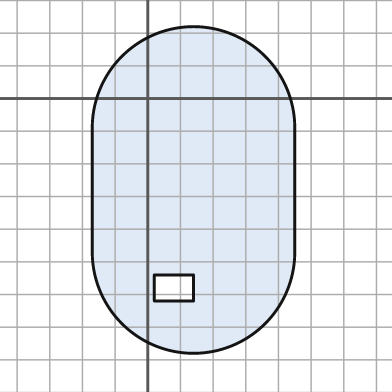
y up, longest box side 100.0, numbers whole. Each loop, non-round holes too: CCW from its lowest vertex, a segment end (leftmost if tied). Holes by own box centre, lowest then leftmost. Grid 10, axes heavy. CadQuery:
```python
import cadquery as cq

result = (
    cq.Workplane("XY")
    .moveTo(-17.0, -47.0)
    .threePointArc((14.0, -78.0), (45.0, -47.0))
    .lineTo(45.0, -9.0)
    .threePointArc((14.0, 22.0), (-17.0, -9.0))
    .close()
    .moveTo(2.0, -62.0)
    .lineTo(14.0, -62.0)
    .lineTo(14.0, -54.0)
    .lineTo(2.0, -54.0)
    .close()
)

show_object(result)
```